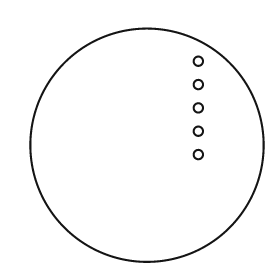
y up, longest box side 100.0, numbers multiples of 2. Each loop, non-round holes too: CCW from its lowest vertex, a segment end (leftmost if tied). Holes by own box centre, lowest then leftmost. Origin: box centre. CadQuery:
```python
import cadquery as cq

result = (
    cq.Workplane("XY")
    .moveTo(0.0, 0.0)
    .circle(50.0)
    .moveTo(22.0, -4.0)
    .circle(2.0)
    .moveTo(22.0, 6.0)
    .circle(2.0)
    .moveTo(22.0, 16.0)
    .circle(2.0)
    .moveTo(22.0, 26.0)
    .circle(2.0)
    .moveTo(22.0, 36.0)
    .circle(2.0)
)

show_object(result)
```